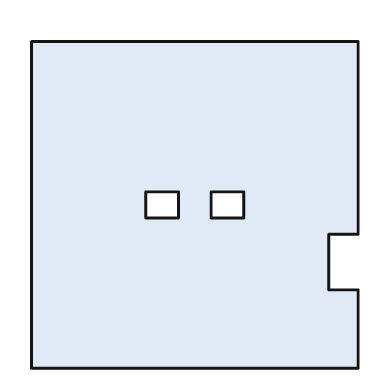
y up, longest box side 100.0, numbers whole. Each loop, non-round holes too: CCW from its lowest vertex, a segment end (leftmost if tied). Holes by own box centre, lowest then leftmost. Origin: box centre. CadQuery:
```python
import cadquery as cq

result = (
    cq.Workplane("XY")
    .moveTo(-50.0, -50.0)
    .lineTo(50.0, -50.0)
    .lineTo(50.0, -26.0)
    .lineTo(41.0, -26.0)
    .lineTo(41.0, -9.0)
    .lineTo(50.0, -9.0)
    .lineTo(50.0, 50.0)
    .lineTo(-50.0, 50.0)
    .close()
    .moveTo(-15.0, -4.0)
    .lineTo(-5.0, -4.0)
    .lineTo(-5.0, 4.0)
    .lineTo(-15.0, 4.0)
    .close()
    .moveTo(5.0, -4.0)
    .lineTo(15.0, -4.0)
    .lineTo(15.0, 4.0)
    .lineTo(5.0, 4.0)
    .close()
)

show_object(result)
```